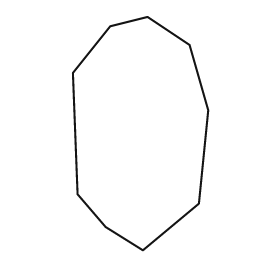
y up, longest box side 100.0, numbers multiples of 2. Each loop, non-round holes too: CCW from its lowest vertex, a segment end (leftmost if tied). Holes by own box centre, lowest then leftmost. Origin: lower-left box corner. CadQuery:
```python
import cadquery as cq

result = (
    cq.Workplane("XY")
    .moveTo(30.0, 0.0)
    .lineTo(54.0, 20.0)
    .lineTo(58.0, 60.0)
    .lineTo(50.0, 88.0)
    .lineTo(32.0, 100.0)
    .lineTo(16.0, 96.0)
    .lineTo(0.0, 76.0)
    .lineTo(2.0, 24.0)
    .lineTo(14.0, 10.0)
    .close()
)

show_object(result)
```